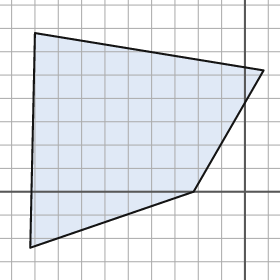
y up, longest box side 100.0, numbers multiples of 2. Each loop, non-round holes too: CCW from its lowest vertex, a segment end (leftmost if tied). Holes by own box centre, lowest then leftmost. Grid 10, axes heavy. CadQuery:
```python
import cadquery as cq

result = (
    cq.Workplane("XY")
    .moveTo(-92.0, -24.0)
    .lineTo(-22.0, 0.0)
    .lineTo(8.0, 52.0)
    .lineTo(-90.0, 68.0)
    .close()
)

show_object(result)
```